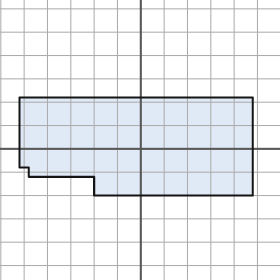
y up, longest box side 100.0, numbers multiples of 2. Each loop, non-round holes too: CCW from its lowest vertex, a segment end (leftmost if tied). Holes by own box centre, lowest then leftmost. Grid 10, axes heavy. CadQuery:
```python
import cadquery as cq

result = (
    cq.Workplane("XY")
    .moveTo(-20.0, -20.0)
    .lineTo(48.0, -20.0)
    .lineTo(48.0, 22.0)
    .lineTo(-52.0, 22.0)
    .lineTo(-52.0, -8.0)
    .lineTo(-48.0, -8.0)
    .lineTo(-48.0, -12.0)
    .lineTo(-20.0, -12.0)
    .close()
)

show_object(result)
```